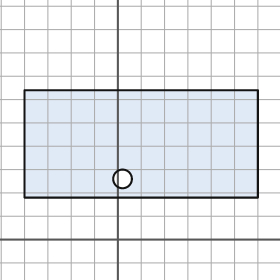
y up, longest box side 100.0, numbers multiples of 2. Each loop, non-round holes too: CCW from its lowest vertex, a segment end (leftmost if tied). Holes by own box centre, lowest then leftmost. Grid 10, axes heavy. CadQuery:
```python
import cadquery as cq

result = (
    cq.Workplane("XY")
    .moveTo(-40.0, 18.0)
    .lineTo(60.0, 18.0)
    .lineTo(60.0, 64.0)
    .lineTo(-40.0, 64.0)
    .close()
    .moveTo(2.0, 26.0)
    .circle(4.0)
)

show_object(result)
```